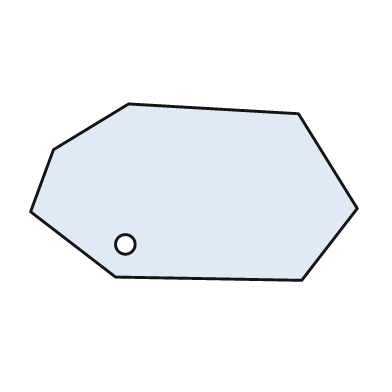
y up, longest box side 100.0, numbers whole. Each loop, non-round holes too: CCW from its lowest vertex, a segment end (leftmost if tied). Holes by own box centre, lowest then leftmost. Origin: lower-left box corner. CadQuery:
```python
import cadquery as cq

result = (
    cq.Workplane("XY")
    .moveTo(83.0, 0.0)
    .lineTo(100.0, 22.0)
    .lineTo(82.0, 51.0)
    .lineTo(30.0, 54.0)
    .lineTo(7.0, 40.0)
    .lineTo(0.0, 21.0)
    .lineTo(26.0, 1.0)
    .close()
    .moveTo(29.0, 11.0)
    .circle(3.0)
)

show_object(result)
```